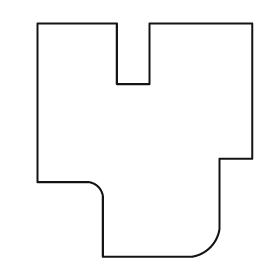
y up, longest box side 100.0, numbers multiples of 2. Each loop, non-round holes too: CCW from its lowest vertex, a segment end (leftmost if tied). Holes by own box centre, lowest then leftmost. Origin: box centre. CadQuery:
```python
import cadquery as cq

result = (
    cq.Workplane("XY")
    .moveTo(-18.0, -50.0)
    .lineTo(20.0, -50.0)
    .threePointArc((28.0, -46.0), (32.0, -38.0))
    .lineTo(32.0, -8.0)
    .lineTo(46.0, -8.0)
    .lineTo(46.0, 50.0)
    .lineTo(2.0, 50.0)
    .lineTo(2.0, 24.0)
    .lineTo(-12.0, 24.0)
    .lineTo(-12.0, 50.0)
    .lineTo(-46.0, 50.0)
    .lineTo(-46.0, -18.0)
    .lineTo(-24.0, -18.0)
    .threePointArc((-20.0, -20.0), (-18.0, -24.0))
    .close()
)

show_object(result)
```